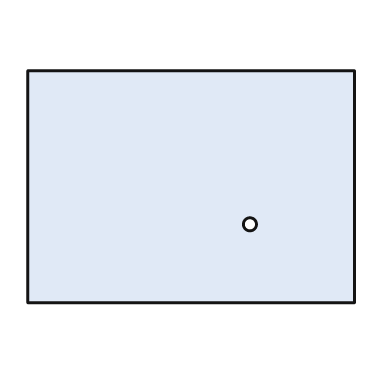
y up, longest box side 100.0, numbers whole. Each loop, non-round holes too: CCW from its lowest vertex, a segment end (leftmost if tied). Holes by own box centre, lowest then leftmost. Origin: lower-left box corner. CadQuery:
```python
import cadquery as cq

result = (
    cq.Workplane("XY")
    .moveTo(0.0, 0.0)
    .lineTo(100.0, 0.0)
    .lineTo(100.0, 71.0)
    .lineTo(0.0, 71.0)
    .close()
    .moveTo(68.0, 24.0)
    .circle(2.0)
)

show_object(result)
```